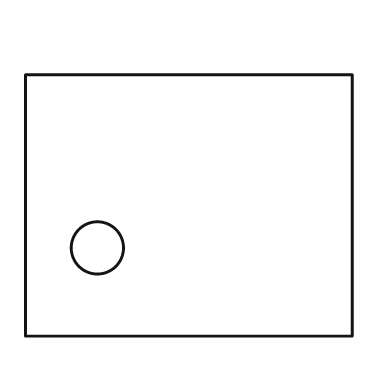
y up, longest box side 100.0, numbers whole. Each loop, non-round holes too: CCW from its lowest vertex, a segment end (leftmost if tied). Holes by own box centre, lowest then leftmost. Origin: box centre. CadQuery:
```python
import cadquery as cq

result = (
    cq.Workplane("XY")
    .moveTo(-50.0, -40.0)
    .lineTo(50.0, -40.0)
    .lineTo(50.0, 40.0)
    .lineTo(-50.0, 40.0)
    .close()
    .moveTo(-28.0, -13.0)
    .circle(8.0)
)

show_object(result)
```